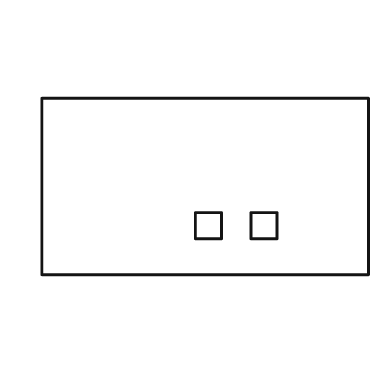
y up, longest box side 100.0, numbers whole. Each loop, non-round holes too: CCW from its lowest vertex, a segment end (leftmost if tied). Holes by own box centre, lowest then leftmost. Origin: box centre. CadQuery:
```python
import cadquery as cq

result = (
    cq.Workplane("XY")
    .moveTo(-50.0, -27.0)
    .lineTo(50.0, -27.0)
    .lineTo(50.0, 27.0)
    .lineTo(-50.0, 27.0)
    .close()
    .moveTo(-3.0, -16.0)
    .lineTo(5.0, -16.0)
    .lineTo(5.0, -8.0)
    .lineTo(-3.0, -8.0)
    .close()
    .moveTo(14.0, -16.0)
    .lineTo(22.0, -16.0)
    .lineTo(22.0, -8.0)
    .lineTo(14.0, -8.0)
    .close()
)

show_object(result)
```